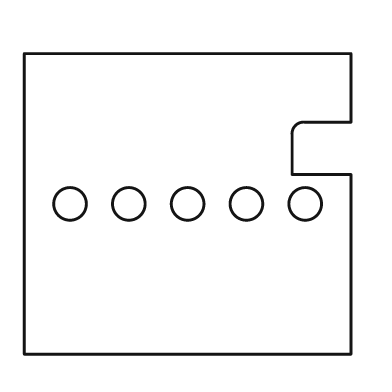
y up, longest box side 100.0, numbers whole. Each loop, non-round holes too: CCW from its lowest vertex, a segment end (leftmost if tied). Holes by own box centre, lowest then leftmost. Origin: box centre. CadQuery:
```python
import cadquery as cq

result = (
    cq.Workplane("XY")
    .moveTo(-50.0, -46.0)
    .lineTo(50.0, -46.0)
    .lineTo(50.0, 9.0)
    .lineTo(32.0, 9.0)
    .lineTo(32.0, 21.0)
    .threePointArc((33.0, 24.0), (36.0, 25.0))
    .lineTo(50.0, 25.0)
    .lineTo(50.0, 46.0)
    .lineTo(-50.0, 46.0)
    .close()
    .moveTo(-36.0, 0.0)
    .circle(5.0)
    .moveTo(-18.0, 0.0)
    .circle(5.0)
    .moveTo(0.0, 0.0)
    .circle(5.0)
    .moveTo(18.0, 0.0)
    .circle(5.0)
    .moveTo(36.0, 0.0)
    .circle(5.0)
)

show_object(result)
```